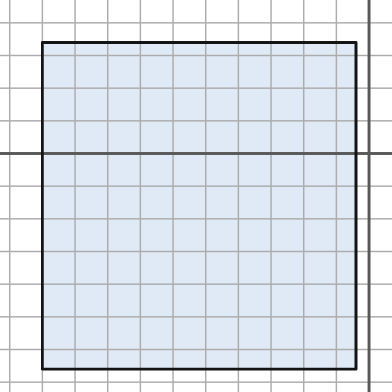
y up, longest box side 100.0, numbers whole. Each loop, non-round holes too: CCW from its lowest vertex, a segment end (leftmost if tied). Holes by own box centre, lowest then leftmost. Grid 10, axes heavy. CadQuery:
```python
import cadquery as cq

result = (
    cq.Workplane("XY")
    .moveTo(-100.0, -66.0)
    .lineTo(-4.0, -66.0)
    .lineTo(-4.0, 34.0)
    .lineTo(-100.0, 34.0)
    .close()
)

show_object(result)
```